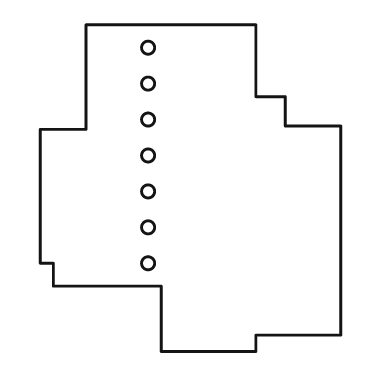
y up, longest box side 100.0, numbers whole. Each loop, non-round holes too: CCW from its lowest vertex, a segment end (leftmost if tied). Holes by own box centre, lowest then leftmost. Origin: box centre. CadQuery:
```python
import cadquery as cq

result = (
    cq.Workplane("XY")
    .moveTo(-9.0, -50.0)
    .lineTo(20.0, -50.0)
    .lineTo(20.0, -45.0)
    .lineTo(46.0, -45.0)
    .lineTo(46.0, 19.0)
    .lineTo(29.0, 19.0)
    .lineTo(29.0, 28.0)
    .lineTo(20.0, 28.0)
    .lineTo(20.0, 50.0)
    .lineTo(-32.0, 50.0)
    .lineTo(-32.0, 18.0)
    .lineTo(-46.0, 18.0)
    .lineTo(-46.0, -23.0)
    .lineTo(-42.0, -23.0)
    .lineTo(-42.0, -30.0)
    .lineTo(-9.0, -30.0)
    .close()
    .moveTo(-13.0, -23.0)
    .circle(2.0)
    .moveTo(-13.0, -12.0)
    .circle(2.0)
    .moveTo(-13.0, -1.0)
    .circle(2.0)
    .moveTo(-13.0, 10.0)
    .circle(2.0)
    .moveTo(-13.0, 21.0)
    .circle(2.0)
    .moveTo(-13.0, 32.0)
    .circle(2.0)
    .moveTo(-13.0, 43.0)
    .circle(2.0)
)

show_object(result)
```